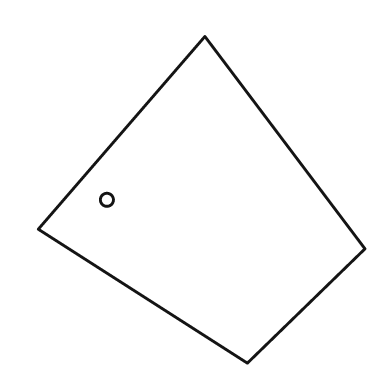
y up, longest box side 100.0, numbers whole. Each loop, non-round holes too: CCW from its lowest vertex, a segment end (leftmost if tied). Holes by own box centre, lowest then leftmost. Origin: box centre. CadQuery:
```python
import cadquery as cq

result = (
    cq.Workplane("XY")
    .moveTo(14.0, -50.0)
    .lineTo(50.0, -15.0)
    .lineTo(1.0, 50.0)
    .lineTo(-50.0, -9.0)
    .close()
    .moveTo(-29.0, 0.0)
    .circle(2.0)
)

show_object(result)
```